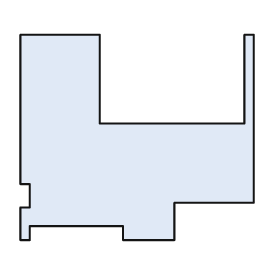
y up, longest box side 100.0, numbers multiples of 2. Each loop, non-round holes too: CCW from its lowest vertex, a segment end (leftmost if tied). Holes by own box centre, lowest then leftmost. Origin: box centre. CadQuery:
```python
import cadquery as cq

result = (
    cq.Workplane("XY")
    .moveTo(-50.0, -44.0)
    .lineTo(-46.0, -44.0)
    .lineTo(-46.0, -38.0)
    .lineTo(-6.0, -38.0)
    .lineTo(-6.0, -44.0)
    .lineTo(16.0, -44.0)
    .lineTo(16.0, -28.0)
    .lineTo(50.0, -28.0)
    .lineTo(50.0, 44.0)
    .lineTo(46.0, 44.0)
    .lineTo(46.0, 6.0)
    .lineTo(-16.0, 6.0)
    .lineTo(-16.0, 44.0)
    .lineTo(-50.0, 44.0)
    .lineTo(-50.0, -20.0)
    .lineTo(-46.0, -20.0)
    .lineTo(-46.0, -30.0)
    .lineTo(-50.0, -30.0)
    .close()
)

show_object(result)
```